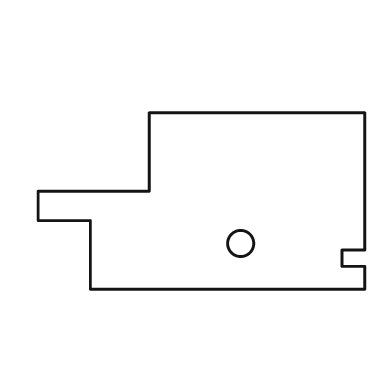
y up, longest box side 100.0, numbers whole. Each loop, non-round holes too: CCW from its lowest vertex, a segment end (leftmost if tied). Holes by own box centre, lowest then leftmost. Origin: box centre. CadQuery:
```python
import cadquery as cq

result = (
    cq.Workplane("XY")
    .moveTo(-34.0, -27.0)
    .lineTo(50.0, -27.0)
    .lineTo(50.0, -20.0)
    .lineTo(43.0, -20.0)
    .lineTo(43.0, -15.0)
    .lineTo(50.0, -15.0)
    .lineTo(50.0, 27.0)
    .lineTo(-16.0, 27.0)
    .lineTo(-16.0, 3.0)
    .lineTo(-50.0, 3.0)
    .lineTo(-50.0, -6.0)
    .lineTo(-34.0, -6.0)
    .close()
    .moveTo(12.0, -13.0)
    .circle(4.0)
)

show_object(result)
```